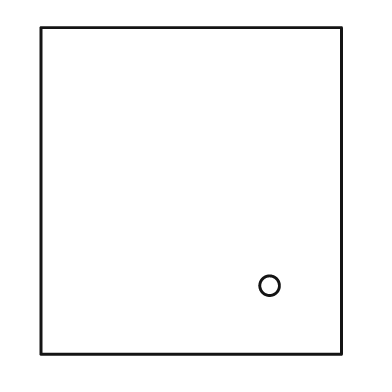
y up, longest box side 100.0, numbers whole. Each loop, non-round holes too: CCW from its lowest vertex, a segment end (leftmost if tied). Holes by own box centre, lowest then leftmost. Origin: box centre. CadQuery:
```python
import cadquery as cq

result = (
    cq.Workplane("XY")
    .moveTo(-46.0, -50.0)
    .lineTo(46.0, -50.0)
    .lineTo(46.0, 50.0)
    .lineTo(-46.0, 50.0)
    .close()
    .moveTo(24.0, -29.0)
    .circle(3.0)
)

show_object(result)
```